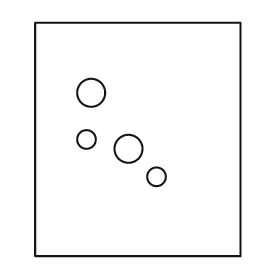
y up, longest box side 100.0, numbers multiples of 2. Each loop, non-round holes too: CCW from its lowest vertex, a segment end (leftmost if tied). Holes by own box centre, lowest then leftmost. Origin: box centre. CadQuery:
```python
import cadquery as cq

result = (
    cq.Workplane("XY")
    .moveTo(-44.0, -50.0)
    .lineTo(44.0, -50.0)
    .lineTo(44.0, 50.0)
    .lineTo(-44.0, 50.0)
    .close()
    .moveTo(8.0, -16.0)
    .circle(4.0)
    .moveTo(-4.0, -4.0)
    .circle(6.0)
    .moveTo(-22.0, 0.0)
    .circle(4.0)
    .moveTo(-20.0, 20.0)
    .circle(6.0)
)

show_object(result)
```